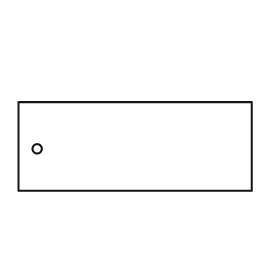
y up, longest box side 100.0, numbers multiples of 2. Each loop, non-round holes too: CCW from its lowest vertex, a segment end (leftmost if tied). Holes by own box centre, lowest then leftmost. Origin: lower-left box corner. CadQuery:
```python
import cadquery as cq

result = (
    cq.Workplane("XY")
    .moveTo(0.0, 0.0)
    .lineTo(100.0, 0.0)
    .lineTo(100.0, 38.0)
    .lineTo(0.0, 38.0)
    .close()
    .moveTo(8.0, 18.0)
    .circle(2.0)
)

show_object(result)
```